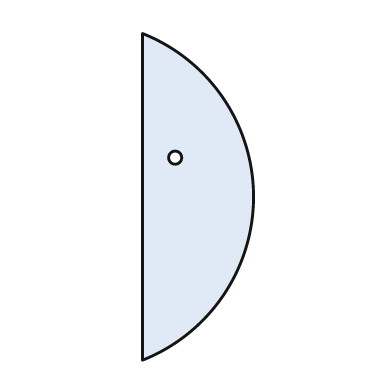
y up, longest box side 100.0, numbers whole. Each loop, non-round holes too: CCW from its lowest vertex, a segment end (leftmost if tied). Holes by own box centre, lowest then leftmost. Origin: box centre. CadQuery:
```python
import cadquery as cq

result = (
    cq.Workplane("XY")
    .moveTo(-17.0, -50.0)
    .threePointArc((17.0, 0.0), (-17.0, 50.0))
    .close()
    .moveTo(-7.0, 12.0)
    .circle(2.0)
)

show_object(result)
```